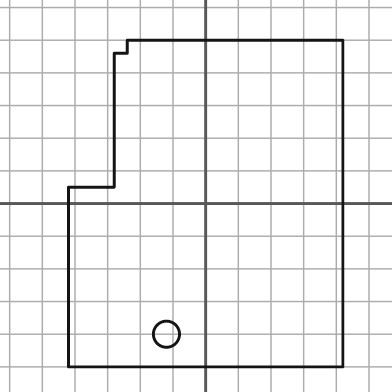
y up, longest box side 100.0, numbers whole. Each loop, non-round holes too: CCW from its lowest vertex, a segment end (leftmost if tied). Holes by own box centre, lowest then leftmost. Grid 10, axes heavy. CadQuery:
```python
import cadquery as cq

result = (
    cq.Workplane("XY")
    .moveTo(-42.0, -50.0)
    .lineTo(42.0, -50.0)
    .lineTo(42.0, 50.0)
    .lineTo(-24.0, 50.0)
    .lineTo(-24.0, 46.0)
    .lineTo(-28.0, 46.0)
    .lineTo(-28.0, 5.0)
    .lineTo(-42.0, 5.0)
    .close()
    .moveTo(-12.0, -40.0)
    .circle(4.0)
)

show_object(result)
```